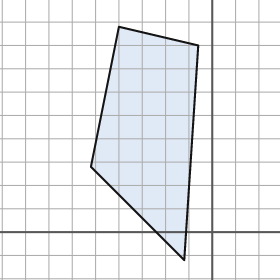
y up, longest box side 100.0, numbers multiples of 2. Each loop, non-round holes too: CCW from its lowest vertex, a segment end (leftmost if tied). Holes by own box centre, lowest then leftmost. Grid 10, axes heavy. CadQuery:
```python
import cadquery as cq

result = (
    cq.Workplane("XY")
    .moveTo(-12.0, -12.0)
    .lineTo(-6.0, 80.0)
    .lineTo(-40.0, 88.0)
    .lineTo(-52.0, 28.0)
    .close()
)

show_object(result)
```